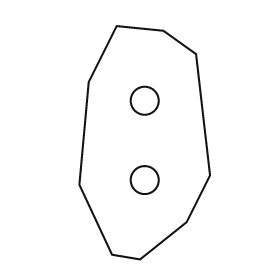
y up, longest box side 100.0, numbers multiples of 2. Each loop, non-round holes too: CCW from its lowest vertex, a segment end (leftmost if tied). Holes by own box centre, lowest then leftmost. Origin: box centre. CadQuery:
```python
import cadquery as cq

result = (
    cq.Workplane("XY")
    .moveTo(-2.0, -50.0)
    .lineTo(18.0, -34.0)
    .lineTo(28.0, -14.0)
    .lineTo(22.0, 38.0)
    .lineTo(8.0, 48.0)
    .lineTo(-12.0, 50.0)
    .lineTo(-24.0, 26.0)
    .lineTo(-28.0, -18.0)
    .lineTo(-14.0, -48.0)
    .close()
    .moveTo(0.0, -16.0)
    .circle(6.0)
    .moveTo(0.0, 18.0)
    .circle(6.0)
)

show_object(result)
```